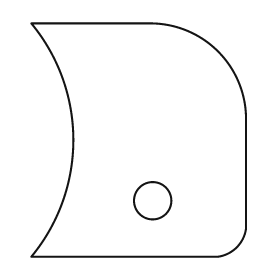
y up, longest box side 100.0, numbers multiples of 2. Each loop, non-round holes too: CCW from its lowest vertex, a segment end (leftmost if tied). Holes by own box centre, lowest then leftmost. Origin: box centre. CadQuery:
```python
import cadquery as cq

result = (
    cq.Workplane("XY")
    .moveTo(-46.0, -50.0)
    .lineTo(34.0, -50.0)
    .threePointArc((42.0, -46.0), (46.0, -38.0))
    .lineTo(46.0, 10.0)
    .threePointArc((34.0, 38.0), (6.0, 50.0))
    .lineTo(-46.0, 50.0)
    .threePointArc((-28.0, 0.0), (-46.0, -50.0))
    .close()
    .moveTo(6.0, -26.0)
    .circle(8.0)
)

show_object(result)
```